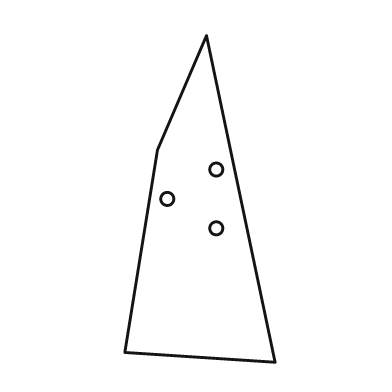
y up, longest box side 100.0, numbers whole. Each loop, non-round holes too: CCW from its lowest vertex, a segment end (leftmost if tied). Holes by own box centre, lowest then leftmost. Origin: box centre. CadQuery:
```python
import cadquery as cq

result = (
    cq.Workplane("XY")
    .moveTo(23.0, -50.0)
    .lineTo(2.0, 50.0)
    .lineTo(-13.0, 15.0)
    .lineTo(-23.0, -47.0)
    .close()
    .moveTo(5.0, -9.0)
    .circle(2.0)
    .moveTo(-10.0, 0.0)
    .circle(2.0)
    .moveTo(5.0, 9.0)
    .circle(2.0)
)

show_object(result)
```